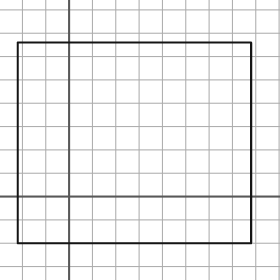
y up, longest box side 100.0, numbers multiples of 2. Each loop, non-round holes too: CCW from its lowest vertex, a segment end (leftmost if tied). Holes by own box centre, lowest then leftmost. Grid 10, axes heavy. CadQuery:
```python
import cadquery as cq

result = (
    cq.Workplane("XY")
    .moveTo(-22.0, -20.0)
    .lineTo(78.0, -20.0)
    .lineTo(78.0, 66.0)
    .lineTo(-22.0, 66.0)
    .close()
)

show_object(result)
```